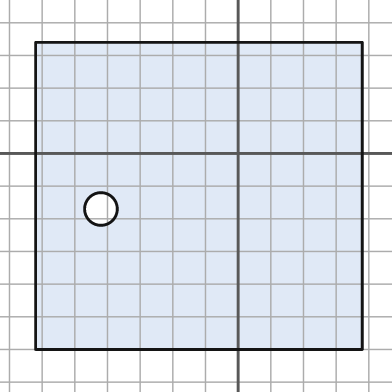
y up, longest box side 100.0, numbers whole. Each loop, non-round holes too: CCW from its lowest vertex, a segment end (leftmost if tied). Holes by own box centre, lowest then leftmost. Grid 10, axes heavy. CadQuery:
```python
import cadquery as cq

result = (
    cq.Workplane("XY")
    .moveTo(-62.0, -60.0)
    .lineTo(38.0, -60.0)
    .lineTo(38.0, 34.0)
    .lineTo(-62.0, 34.0)
    .close()
    .moveTo(-42.0, -17.0)
    .circle(5.0)
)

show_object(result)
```